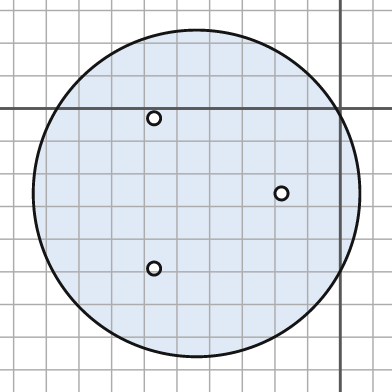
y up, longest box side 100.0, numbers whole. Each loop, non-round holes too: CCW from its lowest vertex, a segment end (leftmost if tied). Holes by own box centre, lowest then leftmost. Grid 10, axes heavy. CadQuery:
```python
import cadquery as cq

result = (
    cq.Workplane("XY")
    .moveTo(-44.0, -26.0)
    .circle(50.0)
    .moveTo(-57.0, -49.0)
    .circle(2.0)
    .moveTo(-18.0, -26.0)
    .circle(2.0)
    .moveTo(-57.0, -3.0)
    .circle(2.0)
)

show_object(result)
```